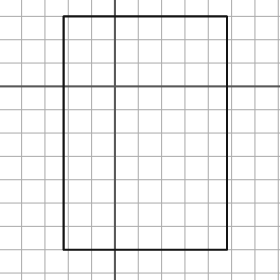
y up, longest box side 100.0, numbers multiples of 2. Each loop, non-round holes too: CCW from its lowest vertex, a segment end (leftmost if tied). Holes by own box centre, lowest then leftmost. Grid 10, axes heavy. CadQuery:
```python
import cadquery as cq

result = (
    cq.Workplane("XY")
    .moveTo(-22.0, -70.0)
    .lineTo(48.0, -70.0)
    .lineTo(48.0, 30.0)
    .lineTo(-22.0, 30.0)
    .close()
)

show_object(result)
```